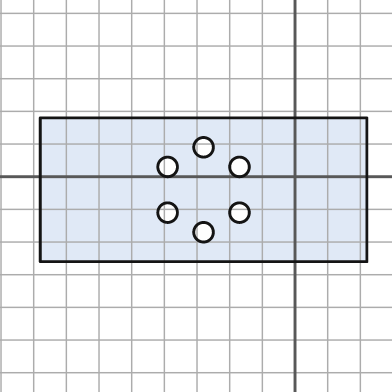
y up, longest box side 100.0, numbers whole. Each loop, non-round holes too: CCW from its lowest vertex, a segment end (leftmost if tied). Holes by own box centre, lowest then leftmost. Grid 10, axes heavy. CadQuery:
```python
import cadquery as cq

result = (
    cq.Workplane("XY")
    .moveTo(-78.0, -26.0)
    .lineTo(22.0, -26.0)
    .lineTo(22.0, 18.0)
    .lineTo(-78.0, 18.0)
    .close()
    .moveTo(-28.0, -17.0)
    .circle(3.0)
    .moveTo(-39.0, -11.0)
    .circle(3.0)
    .moveTo(-17.0, -11.0)
    .circle(3.0)
    .moveTo(-39.0, 3.0)
    .circle(3.0)
    .moveTo(-17.0, 3.0)
    .circle(3.0)
    .moveTo(-28.0, 9.0)
    .circle(3.0)
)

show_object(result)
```